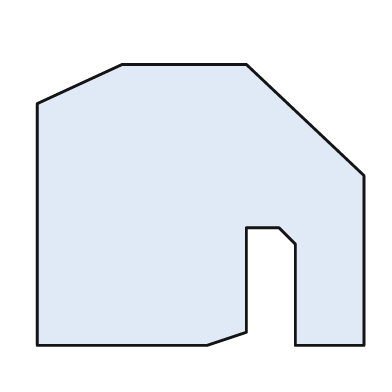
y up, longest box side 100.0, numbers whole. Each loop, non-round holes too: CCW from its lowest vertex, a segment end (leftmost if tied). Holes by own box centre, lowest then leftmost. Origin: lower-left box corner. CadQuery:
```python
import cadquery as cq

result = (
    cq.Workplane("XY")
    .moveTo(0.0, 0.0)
    .lineTo(52.0, 0.0)
    .lineTo(64.0, 4.0)
    .lineTo(64.0, 36.0)
    .lineTo(74.0, 36.0)
    .lineTo(79.0, 31.0)
    .lineTo(79.0, 0.0)
    .lineTo(100.0, 0.0)
    .lineTo(100.0, 52.0)
    .lineTo(64.0, 86.0)
    .lineTo(26.0, 86.0)
    .lineTo(0.0, 74.0)
    .close()
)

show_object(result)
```